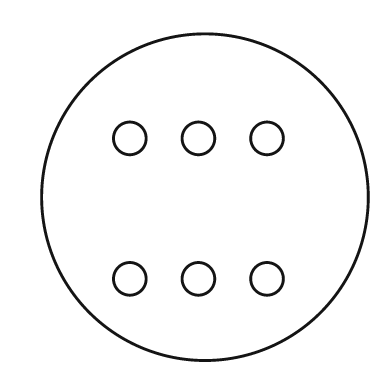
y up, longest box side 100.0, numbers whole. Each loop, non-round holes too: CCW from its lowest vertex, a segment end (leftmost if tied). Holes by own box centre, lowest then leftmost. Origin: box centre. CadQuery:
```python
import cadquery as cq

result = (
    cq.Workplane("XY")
    .moveTo(0.0, 0.0)
    .circle(50.0)
    .moveTo(-23.0, -25.0)
    .circle(5.0)
    .moveTo(-2.0, -25.0)
    .circle(5.0)
    .moveTo(19.0, -25.0)
    .circle(5.0)
    .moveTo(-23.0, 18.0)
    .circle(5.0)
    .moveTo(-2.0, 18.0)
    .circle(5.0)
    .moveTo(19.0, 18.0)
    .circle(5.0)
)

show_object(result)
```